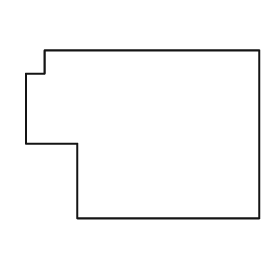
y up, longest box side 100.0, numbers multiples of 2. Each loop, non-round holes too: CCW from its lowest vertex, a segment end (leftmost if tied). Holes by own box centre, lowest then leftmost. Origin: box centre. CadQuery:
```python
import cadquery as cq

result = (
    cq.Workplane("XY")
    .moveTo(-28.0, -36.0)
    .lineTo(50.0, -36.0)
    .lineTo(50.0, 36.0)
    .lineTo(-42.0, 36.0)
    .lineTo(-42.0, 26.0)
    .lineTo(-50.0, 26.0)
    .lineTo(-50.0, -4.0)
    .lineTo(-28.0, -4.0)
    .close()
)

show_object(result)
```